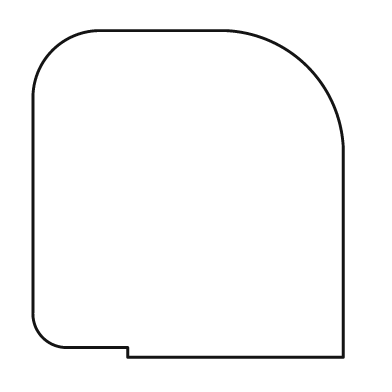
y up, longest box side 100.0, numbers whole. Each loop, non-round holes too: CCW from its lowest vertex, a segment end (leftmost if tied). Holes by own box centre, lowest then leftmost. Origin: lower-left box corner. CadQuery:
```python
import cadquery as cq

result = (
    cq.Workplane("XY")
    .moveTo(29.0, 0.0)
    .lineTo(95.0, 0.0)
    .lineTo(95.0, 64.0)
    .threePointArc((84.0, 89.0), (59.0, 100.0))
    .lineTo(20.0, 100.0)
    .threePointArc((6.0, 94.0), (0.0, 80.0))
    .lineTo(0.0, 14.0)
    .threePointArc((3.0, 6.0), (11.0, 3.0))
    .lineTo(29.0, 3.0)
    .close()
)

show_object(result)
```